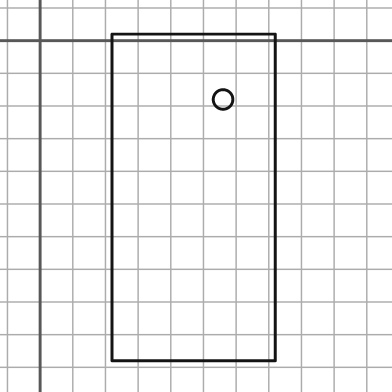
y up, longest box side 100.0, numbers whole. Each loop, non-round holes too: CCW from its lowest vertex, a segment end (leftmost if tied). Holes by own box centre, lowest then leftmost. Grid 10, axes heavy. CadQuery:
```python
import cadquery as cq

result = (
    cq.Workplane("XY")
    .moveTo(22.0, -98.0)
    .lineTo(72.0, -98.0)
    .lineTo(72.0, 2.0)
    .lineTo(22.0, 2.0)
    .close()
    .moveTo(56.0, -18.0)
    .circle(3.0)
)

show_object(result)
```